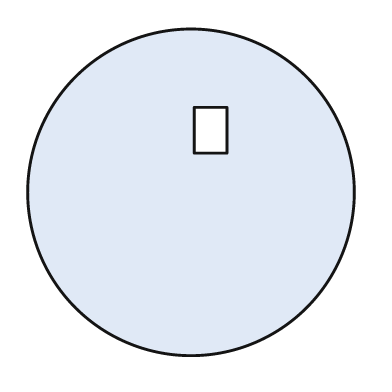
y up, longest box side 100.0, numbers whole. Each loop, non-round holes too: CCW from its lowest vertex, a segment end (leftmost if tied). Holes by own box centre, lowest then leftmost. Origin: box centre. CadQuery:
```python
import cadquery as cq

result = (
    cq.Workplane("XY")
    .moveTo(0.0, 0.0)
    .circle(50.0)
    .moveTo(1.0, 12.0)
    .lineTo(11.0, 12.0)
    .lineTo(11.0, 26.0)
    .lineTo(1.0, 26.0)
    .close()
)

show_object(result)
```